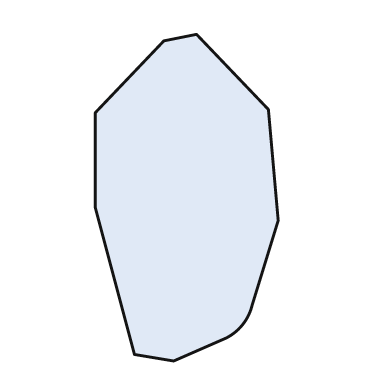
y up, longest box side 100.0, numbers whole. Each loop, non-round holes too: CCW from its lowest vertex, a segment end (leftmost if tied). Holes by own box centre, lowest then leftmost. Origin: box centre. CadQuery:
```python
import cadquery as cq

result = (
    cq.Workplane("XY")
    .moveTo(-4.0, -50.0)
    .lineTo(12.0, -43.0)
    .threePointArc((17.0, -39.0), (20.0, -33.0))
    .lineTo(28.0, -7.0)
    .lineTo(25.0, 27.0)
    .lineTo(3.0, 50.0)
    .lineTo(-7.0, 48.0)
    .lineTo(-28.0, 26.0)
    .lineTo(-28.0, -3.0)
    .lineTo(-16.0, -48.0)
    .close()
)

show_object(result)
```